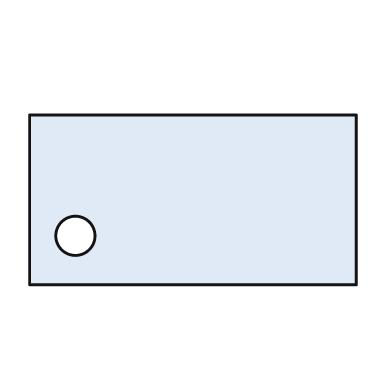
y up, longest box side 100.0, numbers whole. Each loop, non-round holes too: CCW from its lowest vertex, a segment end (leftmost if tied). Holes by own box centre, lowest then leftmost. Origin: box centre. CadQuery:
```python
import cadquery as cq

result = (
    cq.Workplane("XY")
    .moveTo(-50.0, -26.0)
    .lineTo(50.0, -26.0)
    .lineTo(50.0, 26.0)
    .lineTo(-50.0, 26.0)
    .close()
    .moveTo(-36.0, -11.0)
    .circle(6.0)
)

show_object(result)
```